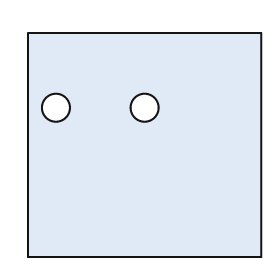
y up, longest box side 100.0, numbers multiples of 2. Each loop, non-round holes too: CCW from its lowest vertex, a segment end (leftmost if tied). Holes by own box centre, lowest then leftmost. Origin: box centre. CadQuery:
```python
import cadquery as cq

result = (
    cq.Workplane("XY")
    .moveTo(-50.0, -48.0)
    .lineTo(50.0, -48.0)
    .lineTo(50.0, 48.0)
    .lineTo(-50.0, 48.0)
    .close()
    .moveTo(-38.0, 16.0)
    .circle(6.0)
    .moveTo(0.0, 16.0)
    .circle(6.0)
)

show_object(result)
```